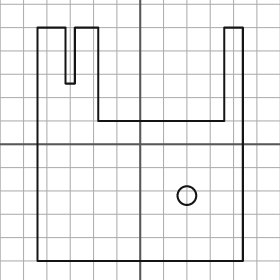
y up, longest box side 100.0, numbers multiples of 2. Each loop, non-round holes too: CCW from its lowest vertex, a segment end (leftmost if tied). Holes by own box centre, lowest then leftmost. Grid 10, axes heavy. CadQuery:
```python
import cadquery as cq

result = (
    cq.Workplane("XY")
    .moveTo(-44.0, -50.0)
    .lineTo(44.0, -50.0)
    .lineTo(44.0, 50.0)
    .lineTo(36.0, 50.0)
    .lineTo(36.0, 10.0)
    .lineTo(-18.0, 10.0)
    .lineTo(-18.0, 50.0)
    .lineTo(-28.0, 50.0)
    .lineTo(-28.0, 26.0)
    .lineTo(-32.0, 26.0)
    .lineTo(-32.0, 50.0)
    .lineTo(-44.0, 50.0)
    .close()
    .moveTo(20.0, -22.0)
    .circle(4.0)
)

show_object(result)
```